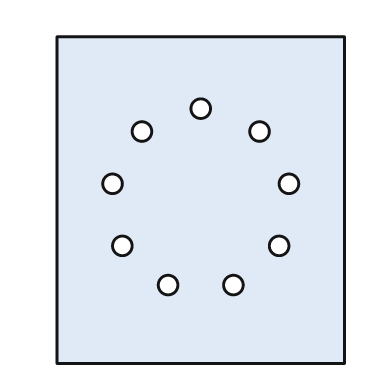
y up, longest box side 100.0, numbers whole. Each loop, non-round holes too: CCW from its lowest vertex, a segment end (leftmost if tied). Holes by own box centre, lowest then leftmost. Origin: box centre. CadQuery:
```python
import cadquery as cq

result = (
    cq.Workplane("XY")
    .moveTo(-44.0, -50.0)
    .lineTo(44.0, -50.0)
    .lineTo(44.0, 50.0)
    .lineTo(-44.0, 50.0)
    .close()
    .moveTo(-10.0, -26.0)
    .circle(3.0)
    .moveTo(10.0, -26.0)
    .circle(3.0)
    .moveTo(-24.0, -14.0)
    .circle(3.0)
    .moveTo(24.0, -14.0)
    .circle(3.0)
    .moveTo(-27.0, 5.0)
    .circle(3.0)
    .moveTo(27.0, 5.0)
    .circle(3.0)
    .moveTo(-18.0, 21.0)
    .circle(3.0)
    .moveTo(18.0, 21.0)
    .circle(3.0)
    .moveTo(0.0, 28.0)
    .circle(3.0)
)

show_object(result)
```